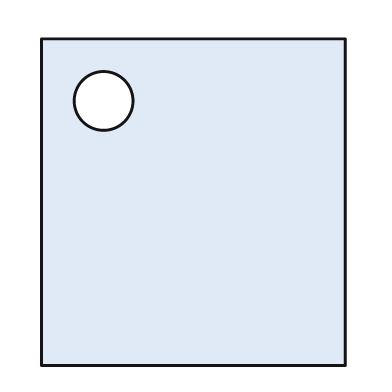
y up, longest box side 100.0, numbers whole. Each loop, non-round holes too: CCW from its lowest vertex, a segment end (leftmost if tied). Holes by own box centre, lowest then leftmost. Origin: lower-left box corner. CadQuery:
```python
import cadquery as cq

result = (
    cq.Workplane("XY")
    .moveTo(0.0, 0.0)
    .lineTo(93.0, 0.0)
    .lineTo(93.0, 100.0)
    .lineTo(0.0, 100.0)
    .close()
    .moveTo(19.0, 81.0)
    .circle(9.0)
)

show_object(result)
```